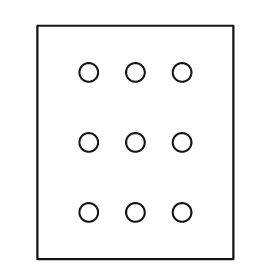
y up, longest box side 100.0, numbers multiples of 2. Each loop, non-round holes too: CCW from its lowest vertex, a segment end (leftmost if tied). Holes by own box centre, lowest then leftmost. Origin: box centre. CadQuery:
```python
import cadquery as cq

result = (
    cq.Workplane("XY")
    .moveTo(-42.0, -50.0)
    .lineTo(42.0, -50.0)
    .lineTo(42.0, 50.0)
    .lineTo(-42.0, 50.0)
    .close()
    .moveTo(-20.0, -30.0)
    .circle(4.0)
    .moveTo(0.0, -30.0)
    .circle(4.0)
    .moveTo(20.0, -30.0)
    .circle(4.0)
    .moveTo(-20.0, 0.0)
    .circle(4.0)
    .moveTo(0.0, 0.0)
    .circle(4.0)
    .moveTo(20.0, 0.0)
    .circle(4.0)
    .moveTo(-20.0, 30.0)
    .circle(4.0)
    .moveTo(0.0, 30.0)
    .circle(4.0)
    .moveTo(20.0, 30.0)
    .circle(4.0)
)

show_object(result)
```